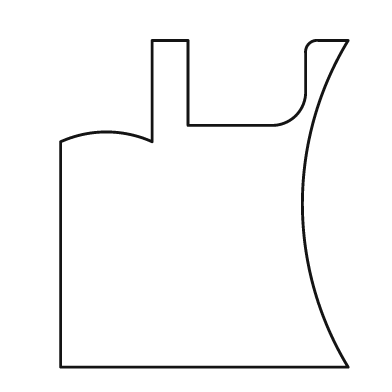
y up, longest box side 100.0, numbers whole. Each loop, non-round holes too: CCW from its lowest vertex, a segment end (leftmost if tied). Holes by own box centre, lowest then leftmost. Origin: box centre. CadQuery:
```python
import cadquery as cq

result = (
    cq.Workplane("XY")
    .moveTo(-44.0, -50.0)
    .lineTo(44.0, -50.0)
    .threePointArc((30.0, 0.0), (44.0, 50.0))
    .lineTo(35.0, 50.0)
    .threePointArc((32.0, 49.0), (31.0, 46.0))
    .lineTo(31.0, 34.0)
    .threePointArc((28.0, 27.0), (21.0, 24.0))
    .lineTo(-5.0, 24.0)
    .lineTo(-5.0, 50.0)
    .lineTo(-16.0, 50.0)
    .lineTo(-16.0, 19.0)
    .threePointArc((-30.0, 22.0), (-44.0, 19.0))
    .close()
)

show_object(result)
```